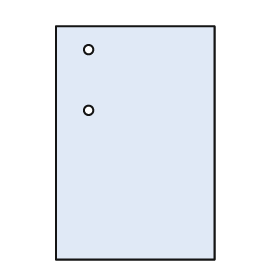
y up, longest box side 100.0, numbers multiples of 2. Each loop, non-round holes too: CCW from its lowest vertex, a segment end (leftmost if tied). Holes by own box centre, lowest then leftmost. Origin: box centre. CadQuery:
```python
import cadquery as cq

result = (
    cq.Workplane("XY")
    .moveTo(-34.0, -50.0)
    .lineTo(34.0, -50.0)
    .lineTo(34.0, 50.0)
    .lineTo(-34.0, 50.0)
    .close()
    .moveTo(-20.0, 14.0)
    .circle(2.0)
    .moveTo(-20.0, 40.0)
    .circle(2.0)
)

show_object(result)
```